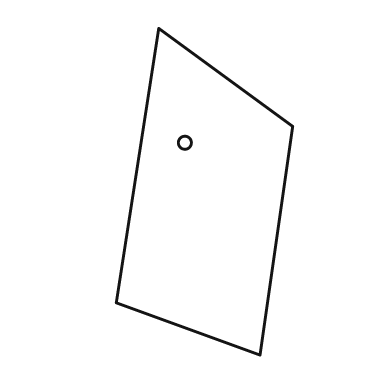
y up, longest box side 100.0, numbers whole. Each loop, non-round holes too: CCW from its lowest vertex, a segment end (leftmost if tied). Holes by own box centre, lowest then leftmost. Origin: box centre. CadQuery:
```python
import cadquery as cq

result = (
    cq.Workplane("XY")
    .moveTo(17.0, -50.0)
    .lineTo(27.0, 20.0)
    .lineTo(-14.0, 50.0)
    .lineTo(-27.0, -34.0)
    .close()
    .moveTo(-6.0, 15.0)
    .circle(2.0)
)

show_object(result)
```